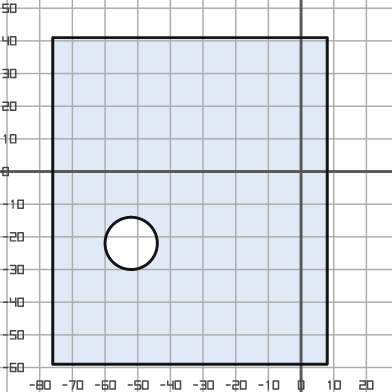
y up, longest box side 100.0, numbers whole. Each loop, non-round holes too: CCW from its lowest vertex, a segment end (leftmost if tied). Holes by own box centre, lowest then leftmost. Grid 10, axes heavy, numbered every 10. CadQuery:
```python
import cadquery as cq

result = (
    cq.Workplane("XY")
    .moveTo(-76.0, -59.0)
    .lineTo(8.0, -59.0)
    .lineTo(8.0, 41.0)
    .lineTo(-76.0, 41.0)
    .close()
    .moveTo(-52.0, -22.0)
    .circle(8.0)
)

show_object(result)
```